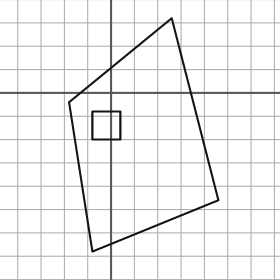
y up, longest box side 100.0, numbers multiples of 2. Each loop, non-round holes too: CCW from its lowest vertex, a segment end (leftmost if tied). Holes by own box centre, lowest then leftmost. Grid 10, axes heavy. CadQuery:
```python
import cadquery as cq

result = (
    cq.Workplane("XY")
    .moveTo(-8.0, -68.0)
    .lineTo(46.0, -46.0)
    .lineTo(26.0, 32.0)
    .lineTo(-18.0, -4.0)
    .close()
    .moveTo(-8.0, -20.0)
    .lineTo(4.0, -20.0)
    .lineTo(4.0, -8.0)
    .lineTo(-8.0, -8.0)
    .close()
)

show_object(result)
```